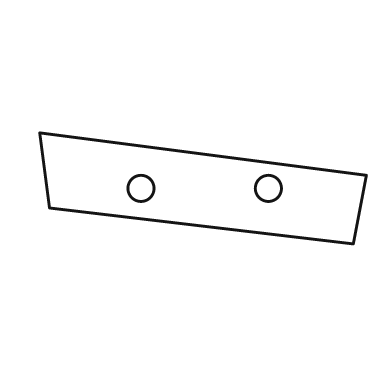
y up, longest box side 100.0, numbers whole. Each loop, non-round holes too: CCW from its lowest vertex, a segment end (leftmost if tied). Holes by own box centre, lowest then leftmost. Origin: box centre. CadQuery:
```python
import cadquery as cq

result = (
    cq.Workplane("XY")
    .moveTo(46.0, -17.0)
    .lineTo(50.0, 4.0)
    .lineTo(-50.0, 17.0)
    .lineTo(-47.0, -6.0)
    .close()
    .moveTo(-19.0, 0.0)
    .circle(4.0)
    .moveTo(20.0, 0.0)
    .circle(4.0)
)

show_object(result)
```